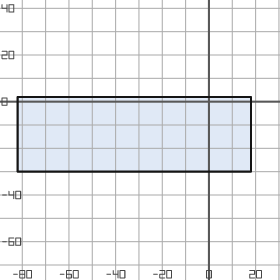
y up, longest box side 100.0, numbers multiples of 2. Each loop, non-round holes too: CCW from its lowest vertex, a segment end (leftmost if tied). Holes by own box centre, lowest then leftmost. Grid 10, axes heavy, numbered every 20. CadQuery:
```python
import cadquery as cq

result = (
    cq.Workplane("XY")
    .moveTo(-82.0, -30.0)
    .lineTo(18.0, -30.0)
    .lineTo(18.0, 2.0)
    .lineTo(-82.0, 2.0)
    .close()
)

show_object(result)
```